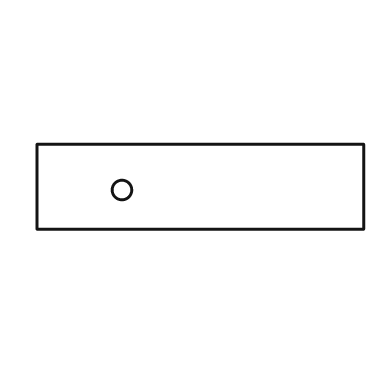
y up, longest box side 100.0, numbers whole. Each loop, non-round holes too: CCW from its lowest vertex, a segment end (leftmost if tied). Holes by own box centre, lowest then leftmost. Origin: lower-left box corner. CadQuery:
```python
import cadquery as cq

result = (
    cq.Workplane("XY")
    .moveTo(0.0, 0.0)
    .lineTo(100.0, 0.0)
    .lineTo(100.0, 26.0)
    .lineTo(0.0, 26.0)
    .close()
    .moveTo(26.0, 12.0)
    .circle(3.0)
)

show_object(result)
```